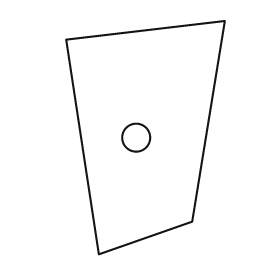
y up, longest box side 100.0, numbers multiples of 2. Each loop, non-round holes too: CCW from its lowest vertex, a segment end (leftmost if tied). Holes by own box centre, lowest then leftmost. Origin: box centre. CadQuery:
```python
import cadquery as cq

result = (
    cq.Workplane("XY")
    .moveTo(-20.0, -50.0)
    .lineTo(20.0, -36.0)
    .lineTo(34.0, 50.0)
    .lineTo(-34.0, 42.0)
    .close()
    .moveTo(-4.0, 0.0)
    .circle(6.0)
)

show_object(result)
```